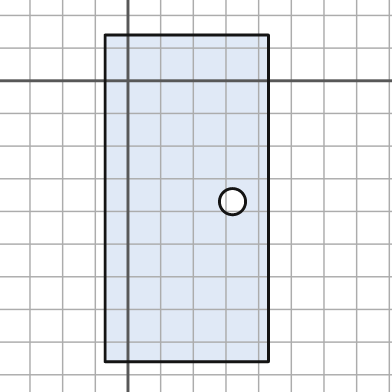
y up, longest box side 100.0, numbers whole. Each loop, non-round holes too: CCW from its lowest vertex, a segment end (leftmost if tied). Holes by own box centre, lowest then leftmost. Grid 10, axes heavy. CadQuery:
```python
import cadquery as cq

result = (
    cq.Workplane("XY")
    .moveTo(-7.0, -86.0)
    .lineTo(43.0, -86.0)
    .lineTo(43.0, 14.0)
    .lineTo(-7.0, 14.0)
    .close()
    .moveTo(32.0, -37.0)
    .circle(4.0)
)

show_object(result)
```